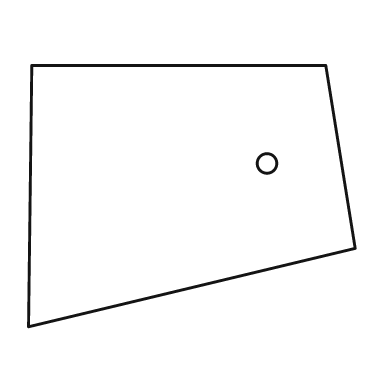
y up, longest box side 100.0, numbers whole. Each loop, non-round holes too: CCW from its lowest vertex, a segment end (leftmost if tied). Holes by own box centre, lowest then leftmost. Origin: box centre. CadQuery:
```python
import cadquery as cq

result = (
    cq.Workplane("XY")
    .moveTo(-50.0, -40.0)
    .lineTo(50.0, -16.0)
    .lineTo(41.0, 40.0)
    .lineTo(-49.0, 40.0)
    .close()
    .moveTo(23.0, 10.0)
    .circle(3.0)
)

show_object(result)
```